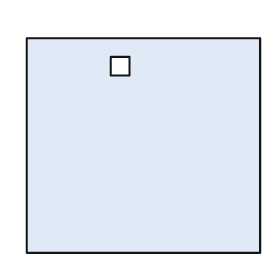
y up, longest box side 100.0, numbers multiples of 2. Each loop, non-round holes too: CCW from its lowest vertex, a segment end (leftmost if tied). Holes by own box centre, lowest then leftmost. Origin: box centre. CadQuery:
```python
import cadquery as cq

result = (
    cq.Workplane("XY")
    .moveTo(-50.0, -46.0)
    .lineTo(50.0, -46.0)
    .lineTo(50.0, 46.0)
    .lineTo(-50.0, 46.0)
    .close()
    .moveTo(-14.0, 30.0)
    .lineTo(-6.0, 30.0)
    .lineTo(-6.0, 38.0)
    .lineTo(-14.0, 38.0)
    .close()
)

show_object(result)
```